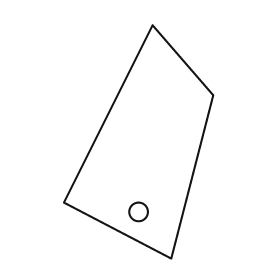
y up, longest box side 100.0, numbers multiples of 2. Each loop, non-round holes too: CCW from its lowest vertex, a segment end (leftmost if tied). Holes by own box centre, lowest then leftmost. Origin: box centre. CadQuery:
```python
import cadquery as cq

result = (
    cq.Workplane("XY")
    .moveTo(14.0, -50.0)
    .lineTo(32.0, 20.0)
    .lineTo(6.0, 50.0)
    .lineTo(-32.0, -26.0)
    .close()
    .moveTo(0.0, -30.0)
    .circle(4.0)
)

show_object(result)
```